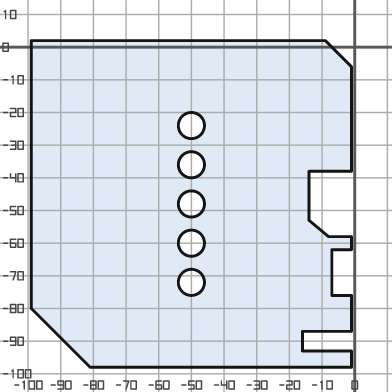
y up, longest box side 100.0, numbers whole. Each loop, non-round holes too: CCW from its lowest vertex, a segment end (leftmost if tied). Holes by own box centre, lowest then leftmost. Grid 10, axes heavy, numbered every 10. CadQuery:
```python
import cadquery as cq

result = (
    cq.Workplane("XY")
    .moveTo(-81.0, -98.0)
    .lineTo(-1.0, -98.0)
    .lineTo(-1.0, -93.0)
    .lineTo(-16.0, -93.0)
    .lineTo(-16.0, -87.0)
    .lineTo(-1.0, -87.0)
    .lineTo(-1.0, -76.0)
    .lineTo(-7.0, -76.0)
    .lineTo(-7.0, -62.0)
    .lineTo(-1.0, -62.0)
    .lineTo(-1.0, -58.0)
    .lineTo(-8.0, -58.0)
    .lineTo(-14.0, -53.0)
    .lineTo(-14.0, -38.0)
    .lineTo(-1.0, -38.0)
    .lineTo(-1.0, -6.0)
    .lineTo(-9.0, 2.0)
    .lineTo(-99.0, 2.0)
    .lineTo(-99.0, -80.0)
    .close()
    .moveTo(-50.0, -72.0)
    .circle(4.0)
    .moveTo(-50.0, -60.0)
    .circle(4.0)
    .moveTo(-50.0, -48.0)
    .circle(4.0)
    .moveTo(-50.0, -36.0)
    .circle(4.0)
    .moveTo(-50.0, -24.0)
    .circle(4.0)
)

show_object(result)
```